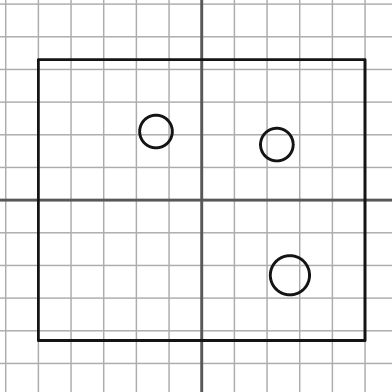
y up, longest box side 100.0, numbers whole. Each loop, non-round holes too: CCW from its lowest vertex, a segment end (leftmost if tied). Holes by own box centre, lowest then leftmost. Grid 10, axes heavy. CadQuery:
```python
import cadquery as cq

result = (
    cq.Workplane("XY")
    .moveTo(-50.0, -43.0)
    .lineTo(50.0, -43.0)
    .lineTo(50.0, 43.0)
    .lineTo(-50.0, 43.0)
    .close()
    .moveTo(27.0, -23.0)
    .circle(6.0)
    .moveTo(23.0, 17.0)
    .circle(5.0)
    .moveTo(-14.0, 21.0)
    .circle(5.0)
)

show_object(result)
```